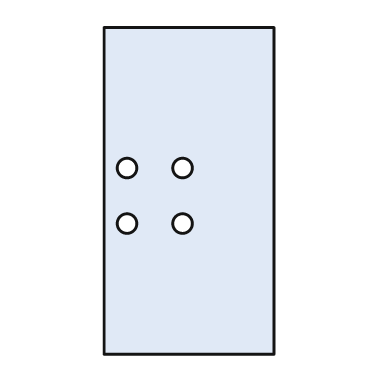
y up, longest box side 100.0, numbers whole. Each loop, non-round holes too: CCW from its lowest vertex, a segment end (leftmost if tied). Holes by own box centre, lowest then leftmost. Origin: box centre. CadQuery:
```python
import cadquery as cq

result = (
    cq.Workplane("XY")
    .moveTo(-26.0, -50.0)
    .lineTo(26.0, -50.0)
    .lineTo(26.0, 50.0)
    .lineTo(-26.0, 50.0)
    .close()
    .moveTo(-19.0, -10.0)
    .circle(3.0)
    .moveTo(-2.0, -10.0)
    .circle(3.0)
    .moveTo(-19.0, 7.0)
    .circle(3.0)
    .moveTo(-2.0, 7.0)
    .circle(3.0)
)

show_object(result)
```